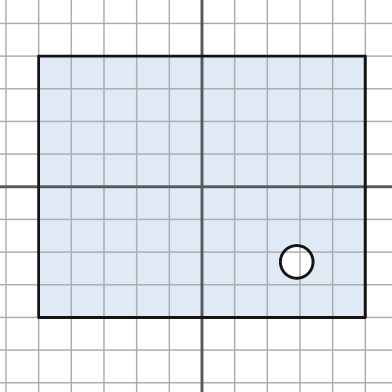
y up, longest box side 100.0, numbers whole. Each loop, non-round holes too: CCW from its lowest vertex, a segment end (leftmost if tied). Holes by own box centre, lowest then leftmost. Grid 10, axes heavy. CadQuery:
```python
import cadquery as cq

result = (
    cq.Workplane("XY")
    .moveTo(-50.0, -40.0)
    .lineTo(50.0, -40.0)
    .lineTo(50.0, 40.0)
    .lineTo(-50.0, 40.0)
    .close()
    .moveTo(29.0, -23.0)
    .circle(5.0)
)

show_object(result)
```